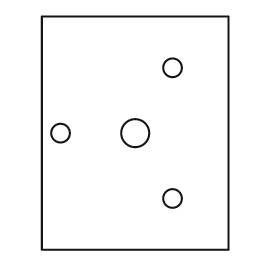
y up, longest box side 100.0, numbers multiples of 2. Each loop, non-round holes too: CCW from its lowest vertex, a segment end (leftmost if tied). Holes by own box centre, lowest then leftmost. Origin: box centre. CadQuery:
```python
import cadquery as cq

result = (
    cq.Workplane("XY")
    .moveTo(-40.0, -50.0)
    .lineTo(40.0, -50.0)
    .lineTo(40.0, 50.0)
    .lineTo(-40.0, 50.0)
    .close()
    .moveTo(16.0, -28.0)
    .circle(4.0)
    .moveTo(-32.0, 0.0)
    .circle(4.0)
    .moveTo(0.0, 0.0)
    .circle(6.0)
    .moveTo(16.0, 28.0)
    .circle(4.0)
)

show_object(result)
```